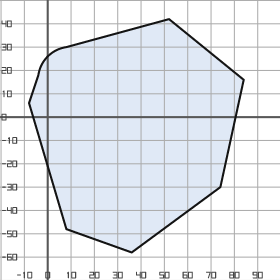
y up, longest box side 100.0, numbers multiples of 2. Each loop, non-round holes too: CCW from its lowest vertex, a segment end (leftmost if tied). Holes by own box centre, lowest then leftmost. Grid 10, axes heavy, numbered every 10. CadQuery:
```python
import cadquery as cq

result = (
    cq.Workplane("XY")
    .moveTo(36.0, -58.0)
    .lineTo(74.0, -30.0)
    .lineTo(84.0, 16.0)
    .lineTo(52.0, 42.0)
    .lineTo(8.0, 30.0)
    .threePointArc((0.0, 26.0), (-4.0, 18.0))
    .lineTo(-8.0, 6.0)
    .lineTo(8.0, -48.0)
    .close()
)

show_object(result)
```